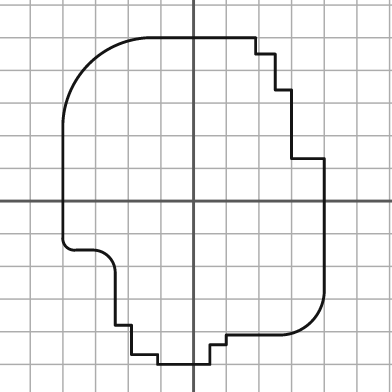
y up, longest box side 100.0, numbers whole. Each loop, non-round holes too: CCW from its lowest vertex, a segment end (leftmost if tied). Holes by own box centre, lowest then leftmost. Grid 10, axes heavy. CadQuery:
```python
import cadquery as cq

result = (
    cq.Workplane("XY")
    .moveTo(-11.0, -50.0)
    .lineTo(5.0, -50.0)
    .lineTo(5.0, -44.0)
    .lineTo(10.0, -44.0)
    .lineTo(10.0, -41.0)
    .lineTo(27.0, -41.0)
    .threePointArc((36.0, -37.0), (40.0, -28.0))
    .lineTo(40.0, 13.0)
    .lineTo(30.0, 13.0)
    .lineTo(30.0, 34.0)
    .lineTo(25.0, 34.0)
    .lineTo(25.0, 45.0)
    .lineTo(19.0, 45.0)
    .lineTo(19.0, 50.0)
    .lineTo(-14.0, 50.0)
    .threePointArc((-32.0, 42.0), (-40.0, 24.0))
    .lineTo(-40.0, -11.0)
    .threePointArc((-39.0, -14.0), (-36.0, -15.0))
    .lineTo(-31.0, -15.0)
    .threePointArc((-26.0, -17.0), (-24.0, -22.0))
    .lineTo(-24.0, -38.0)
    .lineTo(-19.0, -38.0)
    .lineTo(-19.0, -47.0)
    .lineTo(-11.0, -47.0)
    .close()
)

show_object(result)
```